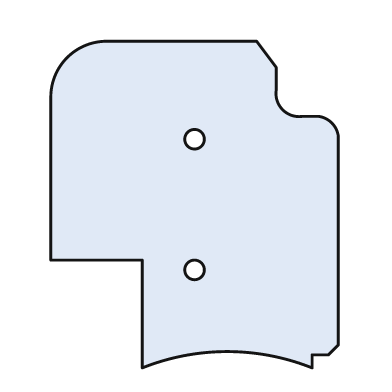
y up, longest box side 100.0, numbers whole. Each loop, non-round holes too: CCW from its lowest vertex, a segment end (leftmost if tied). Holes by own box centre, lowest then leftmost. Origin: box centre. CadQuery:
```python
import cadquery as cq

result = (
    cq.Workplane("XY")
    .moveTo(-16.0, -50.0)
    .threePointArc((10.0, -45.0), (36.0, -50.0))
    .lineTo(36.0, -46.0)
    .lineTo(41.0, -46.0)
    .lineTo(44.0, -43.0)
    .lineTo(44.0, 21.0)
    .threePointArc((42.0, 25.0), (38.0, 27.0))
    .lineTo(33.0, 27.0)
    .threePointArc((27.0, 29.0), (25.0, 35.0))
    .lineTo(25.0, 42.0)
    .lineTo(19.0, 50.0)
    .lineTo(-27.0, 50.0)
    .threePointArc((-39.0, 45.0), (-44.0, 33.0))
    .lineTo(-44.0, -17.0)
    .lineTo(-16.0, -17.0)
    .close()
    .moveTo(0.0, -20.0)
    .circle(3.0)
    .moveTo(0.0, 20.0)
    .circle(3.0)
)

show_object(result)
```